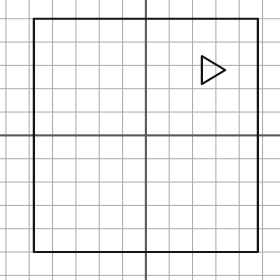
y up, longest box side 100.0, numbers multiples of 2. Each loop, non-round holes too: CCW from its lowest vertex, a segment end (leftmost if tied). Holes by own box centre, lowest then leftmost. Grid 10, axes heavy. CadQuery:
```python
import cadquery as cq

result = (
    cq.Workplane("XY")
    .moveTo(-48.0, -50.0)
    .lineTo(48.0, -50.0)
    .lineTo(48.0, 50.0)
    .lineTo(-48.0, 50.0)
    .close()
    .moveTo(24.0, 22.0)
    .lineTo(34.0, 28.0)
    .lineTo(24.0, 34.0)
    .close()
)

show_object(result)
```